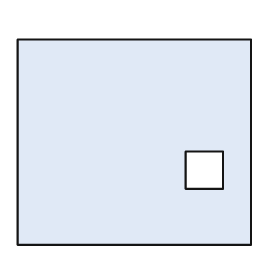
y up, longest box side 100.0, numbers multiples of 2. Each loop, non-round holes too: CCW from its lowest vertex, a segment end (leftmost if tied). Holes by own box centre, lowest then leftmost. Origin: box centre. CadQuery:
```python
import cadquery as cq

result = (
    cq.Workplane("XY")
    .moveTo(-50.0, -44.0)
    .lineTo(50.0, -44.0)
    .lineTo(50.0, 44.0)
    .lineTo(-50.0, 44.0)
    .close()
    .moveTo(22.0, -20.0)
    .lineTo(38.0, -20.0)
    .lineTo(38.0, -4.0)
    .lineTo(22.0, -4.0)
    .close()
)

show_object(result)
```